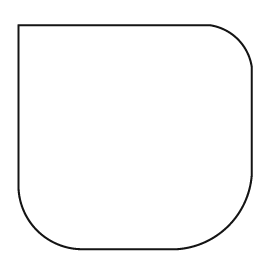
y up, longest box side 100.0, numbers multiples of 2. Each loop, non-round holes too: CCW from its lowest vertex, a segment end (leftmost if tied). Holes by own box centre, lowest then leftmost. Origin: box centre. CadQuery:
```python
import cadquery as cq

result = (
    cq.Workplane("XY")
    .moveTo(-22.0, -48.0)
    .lineTo(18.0, -48.0)
    .threePointArc((40.0, -38.0), (50.0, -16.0))
    .lineTo(50.0, 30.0)
    .threePointArc((44.0, 42.0), (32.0, 48.0))
    .lineTo(-50.0, 48.0)
    .lineTo(-50.0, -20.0)
    .threePointArc((-42.0, -40.0), (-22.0, -48.0))
    .close()
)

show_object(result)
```